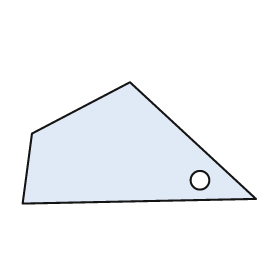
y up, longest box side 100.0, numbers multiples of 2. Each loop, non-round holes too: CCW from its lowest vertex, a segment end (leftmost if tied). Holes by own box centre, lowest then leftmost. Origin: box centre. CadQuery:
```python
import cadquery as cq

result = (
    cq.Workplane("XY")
    .moveTo(-50.0, -26.0)
    .lineTo(50.0, -24.0)
    .lineTo(-4.0, 26.0)
    .lineTo(-46.0, 4.0)
    .close()
    .moveTo(26.0, -16.0)
    .circle(4.0)
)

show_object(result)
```